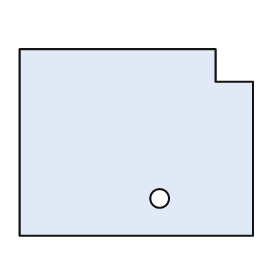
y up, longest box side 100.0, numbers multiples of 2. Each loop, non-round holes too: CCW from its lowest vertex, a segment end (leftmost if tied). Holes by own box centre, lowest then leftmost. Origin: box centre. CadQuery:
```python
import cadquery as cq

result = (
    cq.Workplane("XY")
    .moveTo(-50.0, -40.0)
    .lineTo(50.0, -40.0)
    .lineTo(50.0, 26.0)
    .lineTo(34.0, 26.0)
    .lineTo(34.0, 40.0)
    .lineTo(-50.0, 40.0)
    .close()
    .moveTo(10.0, -24.0)
    .circle(4.0)
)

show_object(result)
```